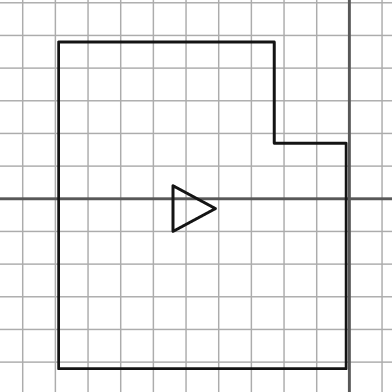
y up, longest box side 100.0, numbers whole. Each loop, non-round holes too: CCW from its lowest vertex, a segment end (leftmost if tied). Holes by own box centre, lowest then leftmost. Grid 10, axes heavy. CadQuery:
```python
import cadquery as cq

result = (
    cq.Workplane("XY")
    .moveTo(-89.0, -52.0)
    .lineTo(-1.0, -52.0)
    .lineTo(-1.0, 17.0)
    .lineTo(-23.0, 17.0)
    .lineTo(-23.0, 48.0)
    .lineTo(-89.0, 48.0)
    .close()
    .moveTo(-54.0, -10.0)
    .lineTo(-41.0, -3.0)
    .lineTo(-54.0, 4.0)
    .close()
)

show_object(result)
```